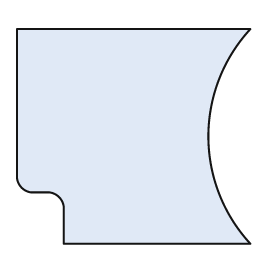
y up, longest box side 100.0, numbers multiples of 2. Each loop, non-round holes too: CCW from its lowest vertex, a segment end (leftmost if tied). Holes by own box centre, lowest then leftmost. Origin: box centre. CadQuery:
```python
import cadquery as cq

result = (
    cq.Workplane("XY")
    .moveTo(-30.0, -46.0)
    .lineTo(50.0, -46.0)
    .threePointArc((32.0, 0.0), (50.0, 46.0))
    .lineTo(-50.0, 46.0)
    .lineTo(-50.0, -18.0)
    .threePointArc((-48.0, -22.0), (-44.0, -24.0))
    .lineTo(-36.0, -24.0)
    .threePointArc((-32.0, -26.0), (-30.0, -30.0))
    .close()
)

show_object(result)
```